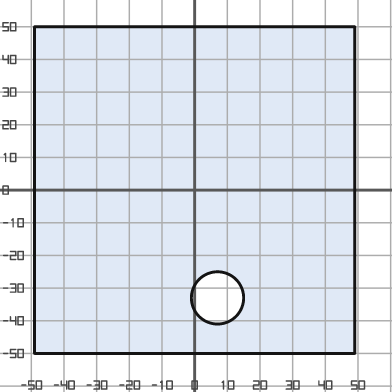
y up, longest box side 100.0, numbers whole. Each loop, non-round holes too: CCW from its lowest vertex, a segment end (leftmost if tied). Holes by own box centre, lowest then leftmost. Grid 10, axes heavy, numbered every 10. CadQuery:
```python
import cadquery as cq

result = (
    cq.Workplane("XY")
    .moveTo(-49.0, -50.0)
    .lineTo(49.0, -50.0)
    .lineTo(49.0, 50.0)
    .lineTo(-49.0, 50.0)
    .close()
    .moveTo(7.0, -33.0)
    .circle(8.0)
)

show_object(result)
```